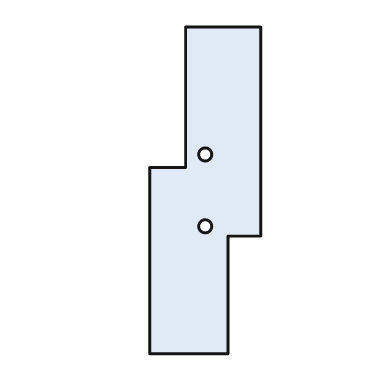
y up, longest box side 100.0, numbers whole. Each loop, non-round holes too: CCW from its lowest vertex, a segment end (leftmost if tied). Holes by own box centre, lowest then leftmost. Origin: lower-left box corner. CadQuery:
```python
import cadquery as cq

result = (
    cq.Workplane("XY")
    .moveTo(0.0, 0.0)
    .lineTo(24.0, 0.0)
    .lineTo(24.0, 36.0)
    .lineTo(34.0, 36.0)
    .lineTo(34.0, 100.0)
    .lineTo(11.0, 100.0)
    .lineTo(11.0, 57.0)
    .lineTo(0.0, 57.0)
    .close()
    .moveTo(17.0, 39.0)
    .circle(2.0)
    .moveTo(17.0, 61.0)
    .circle(2.0)
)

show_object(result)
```